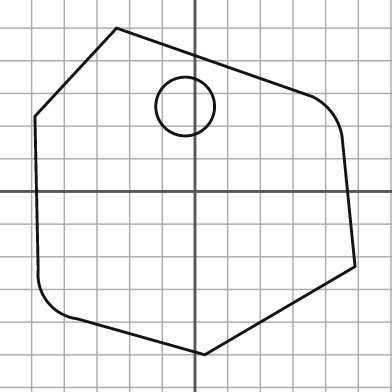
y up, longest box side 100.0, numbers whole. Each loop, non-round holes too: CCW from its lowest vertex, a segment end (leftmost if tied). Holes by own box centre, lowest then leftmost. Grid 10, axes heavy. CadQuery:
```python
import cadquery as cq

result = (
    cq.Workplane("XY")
    .moveTo(3.0, -50.0)
    .lineTo(49.0, -23.0)
    .lineTo(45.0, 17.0)
    .threePointArc((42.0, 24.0), (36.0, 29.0))
    .lineTo(-24.0, 50.0)
    .lineTo(-49.0, 23.0)
    .lineTo(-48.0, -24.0)
    .threePointArc((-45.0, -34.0), (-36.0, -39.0))
    .close()
    .moveTo(-3.0, 26.0)
    .circle(9.0)
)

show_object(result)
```